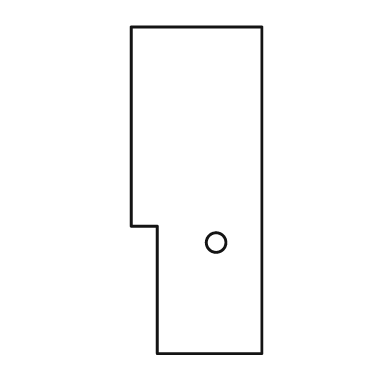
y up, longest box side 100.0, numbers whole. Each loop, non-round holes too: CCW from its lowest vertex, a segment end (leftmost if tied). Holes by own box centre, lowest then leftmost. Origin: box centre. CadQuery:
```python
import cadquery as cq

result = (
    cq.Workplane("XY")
    .moveTo(-12.0, -50.0)
    .lineTo(20.0, -50.0)
    .lineTo(20.0, 50.0)
    .lineTo(-20.0, 50.0)
    .lineTo(-20.0, -11.0)
    .lineTo(-12.0, -11.0)
    .close()
    .moveTo(6.0, -16.0)
    .circle(3.0)
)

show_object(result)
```